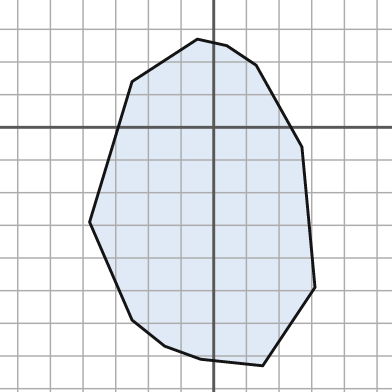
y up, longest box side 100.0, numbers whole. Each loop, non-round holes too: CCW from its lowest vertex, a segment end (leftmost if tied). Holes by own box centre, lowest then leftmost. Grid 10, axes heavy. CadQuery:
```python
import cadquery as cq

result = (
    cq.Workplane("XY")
    .moveTo(15.0, -73.0)
    .lineTo(31.0, -49.0)
    .lineTo(27.0, -6.0)
    .lineTo(13.0, 19.0)
    .lineTo(4.0, 25.0)
    .lineTo(-5.0, 27.0)
    .lineTo(-25.0, 14.0)
    .lineTo(-38.0, -29.0)
    .lineTo(-25.0, -59.0)
    .lineTo(-15.0, -67.0)
    .lineTo(-4.0, -71.0)
    .close()
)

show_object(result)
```